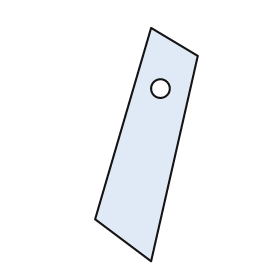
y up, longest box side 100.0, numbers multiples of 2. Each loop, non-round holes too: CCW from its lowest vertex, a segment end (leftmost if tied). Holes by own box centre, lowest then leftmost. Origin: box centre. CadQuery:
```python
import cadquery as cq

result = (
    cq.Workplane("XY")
    .moveTo(2.0, -50.0)
    .lineTo(22.0, 38.0)
    .lineTo(2.0, 50.0)
    .lineTo(-22.0, -32.0)
    .close()
    .moveTo(6.0, 24.0)
    .circle(4.0)
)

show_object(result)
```